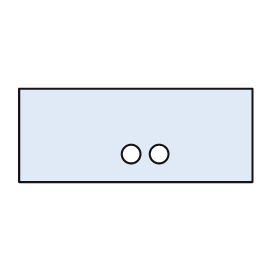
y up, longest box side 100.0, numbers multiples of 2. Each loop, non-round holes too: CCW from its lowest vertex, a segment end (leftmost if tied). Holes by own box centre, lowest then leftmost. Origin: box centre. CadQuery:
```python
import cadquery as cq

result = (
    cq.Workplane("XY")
    .moveTo(-50.0, -20.0)
    .lineTo(50.0, -20.0)
    .lineTo(50.0, 20.0)
    .lineTo(-50.0, 20.0)
    .close()
    .moveTo(-2.0, -8.0)
    .circle(4.0)
    .moveTo(10.0, -8.0)
    .circle(4.0)
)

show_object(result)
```